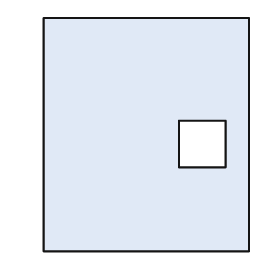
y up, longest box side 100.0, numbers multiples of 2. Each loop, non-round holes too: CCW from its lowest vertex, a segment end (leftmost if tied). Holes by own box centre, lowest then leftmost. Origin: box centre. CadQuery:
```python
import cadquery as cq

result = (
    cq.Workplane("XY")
    .moveTo(-44.0, -50.0)
    .lineTo(44.0, -50.0)
    .lineTo(44.0, 50.0)
    .lineTo(-44.0, 50.0)
    .close()
    .moveTo(14.0, -14.0)
    .lineTo(34.0, -14.0)
    .lineTo(34.0, 6.0)
    .lineTo(14.0, 6.0)
    .close()
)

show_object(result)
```